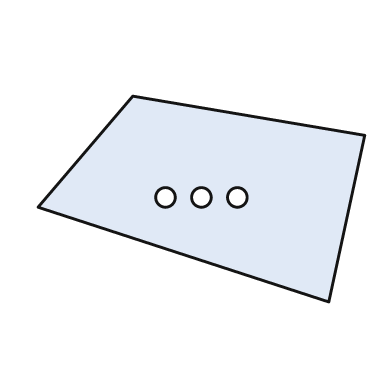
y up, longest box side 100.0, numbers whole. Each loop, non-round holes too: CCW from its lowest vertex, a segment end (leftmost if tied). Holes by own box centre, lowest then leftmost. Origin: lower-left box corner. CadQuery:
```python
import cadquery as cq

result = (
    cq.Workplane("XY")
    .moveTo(89.0, 0.0)
    .lineTo(100.0, 51.0)
    .lineTo(29.0, 63.0)
    .lineTo(0.0, 29.0)
    .close()
    .moveTo(39.0, 32.0)
    .circle(3.0)
    .moveTo(50.0, 32.0)
    .circle(3.0)
    .moveTo(61.0, 32.0)
    .circle(3.0)
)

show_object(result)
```